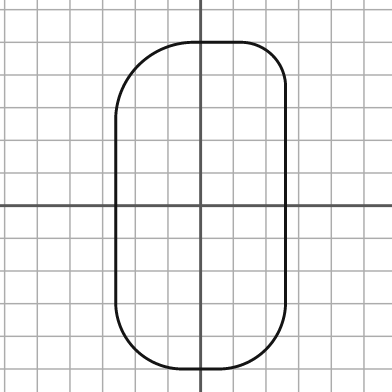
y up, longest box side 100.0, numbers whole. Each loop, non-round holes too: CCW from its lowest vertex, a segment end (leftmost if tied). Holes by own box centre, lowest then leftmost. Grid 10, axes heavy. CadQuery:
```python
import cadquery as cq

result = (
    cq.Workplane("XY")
    .moveTo(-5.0, -50.0)
    .lineTo(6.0, -50.0)
    .threePointArc((20.0, -44.0), (26.0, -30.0))
    .lineTo(26.0, 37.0)
    .threePointArc((22.0, 46.0), (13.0, 50.0))
    .lineTo(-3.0, 50.0)
    .threePointArc((-19.0, 43.0), (-26.0, 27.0))
    .lineTo(-26.0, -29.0)
    .threePointArc((-20.0, -44.0), (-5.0, -50.0))
    .close()
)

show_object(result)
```